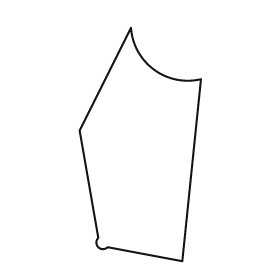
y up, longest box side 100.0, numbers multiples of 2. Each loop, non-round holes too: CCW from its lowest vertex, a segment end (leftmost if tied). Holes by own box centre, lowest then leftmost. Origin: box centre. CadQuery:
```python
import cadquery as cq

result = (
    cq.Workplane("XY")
    .moveTo(18.0, -50.0)
    .lineTo(26.0, 28.0)
    .threePointArc((6.0, 32.0), (-4.0, 50.0))
    .lineTo(-26.0, 6.0)
    .lineTo(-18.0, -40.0)
    .threePointArc((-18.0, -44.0), (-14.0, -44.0))
    .close()
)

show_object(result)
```